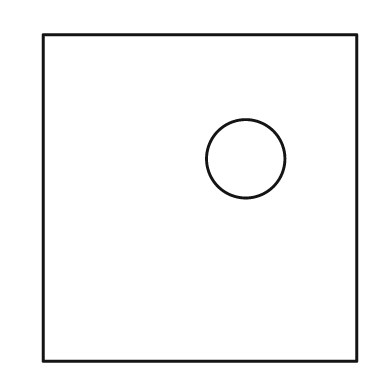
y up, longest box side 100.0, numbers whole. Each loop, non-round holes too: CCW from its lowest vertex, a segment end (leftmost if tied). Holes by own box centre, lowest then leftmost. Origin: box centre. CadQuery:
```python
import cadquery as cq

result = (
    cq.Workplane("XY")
    .moveTo(-48.0, -50.0)
    .lineTo(48.0, -50.0)
    .lineTo(48.0, 50.0)
    .lineTo(-48.0, 50.0)
    .close()
    .moveTo(14.0, 12.0)
    .circle(12.0)
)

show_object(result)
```